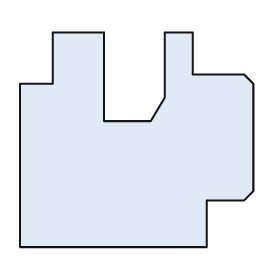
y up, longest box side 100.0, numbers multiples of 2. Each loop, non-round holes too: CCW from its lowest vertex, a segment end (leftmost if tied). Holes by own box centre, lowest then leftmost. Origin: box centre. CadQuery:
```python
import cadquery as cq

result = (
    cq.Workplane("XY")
    .moveTo(-50.0, -46.0)
    .lineTo(30.0, -46.0)
    .lineTo(30.0, -26.0)
    .lineTo(46.0, -26.0)
    .lineTo(50.0, -22.0)
    .lineTo(50.0, 24.0)
    .lineTo(46.0, 28.0)
    .lineTo(24.0, 28.0)
    .lineTo(24.0, 46.0)
    .lineTo(12.0, 46.0)
    .lineTo(12.0, 18.0)
    .lineTo(6.0, 8.0)
    .lineTo(-14.0, 8.0)
    .lineTo(-14.0, 46.0)
    .lineTo(-36.0, 46.0)
    .lineTo(-36.0, 24.0)
    .lineTo(-50.0, 24.0)
    .close()
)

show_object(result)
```